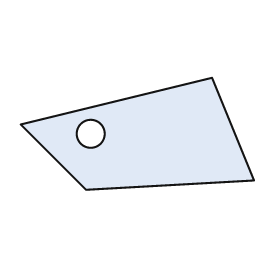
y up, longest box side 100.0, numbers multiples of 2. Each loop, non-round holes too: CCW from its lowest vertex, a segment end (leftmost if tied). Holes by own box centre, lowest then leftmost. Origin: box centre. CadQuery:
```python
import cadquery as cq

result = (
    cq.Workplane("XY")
    .moveTo(-22.0, -24.0)
    .lineTo(50.0, -20.0)
    .lineTo(32.0, 24.0)
    .lineTo(-50.0, 4.0)
    .close()
    .moveTo(-20.0, 0.0)
    .circle(6.0)
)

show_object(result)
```